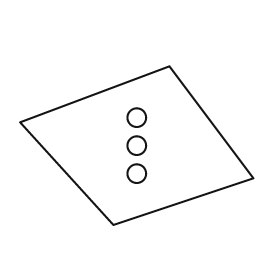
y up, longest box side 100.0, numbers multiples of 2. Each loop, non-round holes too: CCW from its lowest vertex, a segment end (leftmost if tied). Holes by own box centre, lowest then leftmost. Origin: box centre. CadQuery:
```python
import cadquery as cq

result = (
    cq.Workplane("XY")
    .moveTo(-10.0, -34.0)
    .lineTo(50.0, -14.0)
    .lineTo(14.0, 34.0)
    .lineTo(-50.0, 10.0)
    .close()
    .moveTo(0.0, -12.0)
    .circle(4.0)
    .moveTo(0.0, 0.0)
    .circle(4.0)
    .moveTo(0.0, 12.0)
    .circle(4.0)
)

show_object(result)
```